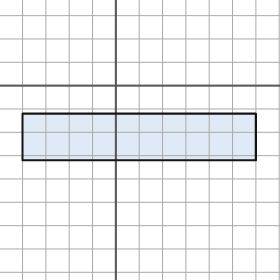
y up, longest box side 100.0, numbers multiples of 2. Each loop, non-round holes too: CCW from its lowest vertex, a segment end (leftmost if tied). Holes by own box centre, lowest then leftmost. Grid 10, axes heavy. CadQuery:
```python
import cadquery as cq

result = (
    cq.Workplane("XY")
    .moveTo(-40.0, -32.0)
    .lineTo(60.0, -32.0)
    .lineTo(60.0, -12.0)
    .lineTo(-40.0, -12.0)
    .close()
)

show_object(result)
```